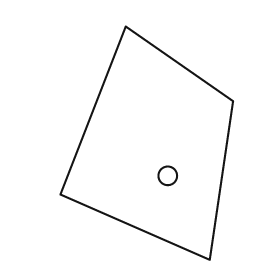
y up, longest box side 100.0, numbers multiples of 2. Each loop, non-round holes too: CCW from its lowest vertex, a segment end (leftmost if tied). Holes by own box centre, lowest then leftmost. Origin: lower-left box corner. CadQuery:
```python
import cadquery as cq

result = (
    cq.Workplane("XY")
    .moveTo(64.0, 0.0)
    .lineTo(74.0, 68.0)
    .lineTo(28.0, 100.0)
    .lineTo(0.0, 28.0)
    .close()
    .moveTo(46.0, 36.0)
    .circle(4.0)
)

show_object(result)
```